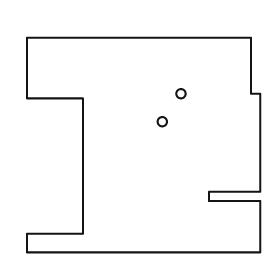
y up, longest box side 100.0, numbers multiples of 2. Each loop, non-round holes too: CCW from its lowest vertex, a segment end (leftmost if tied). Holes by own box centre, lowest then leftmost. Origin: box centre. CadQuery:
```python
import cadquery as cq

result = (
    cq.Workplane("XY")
    .moveTo(-50.0, -46.0)
    .lineTo(50.0, -46.0)
    .lineTo(50.0, -24.0)
    .lineTo(28.0, -24.0)
    .lineTo(28.0, -20.0)
    .lineTo(50.0, -20.0)
    .lineTo(50.0, 22.0)
    .lineTo(46.0, 22.0)
    .lineTo(46.0, 46.0)
    .lineTo(-50.0, 46.0)
    .lineTo(-50.0, 20.0)
    .lineTo(-26.0, 20.0)
    .lineTo(-26.0, -38.0)
    .lineTo(-50.0, -38.0)
    .close()
    .moveTo(8.0, 10.0)
    .circle(2.0)
    .moveTo(16.0, 22.0)
    .circle(2.0)
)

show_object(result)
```